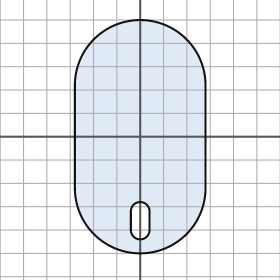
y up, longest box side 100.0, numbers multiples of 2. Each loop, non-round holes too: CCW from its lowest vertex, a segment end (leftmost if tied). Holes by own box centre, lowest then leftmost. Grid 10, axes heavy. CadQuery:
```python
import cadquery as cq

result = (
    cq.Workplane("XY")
    .moveTo(-28.0, -22.0)
    .threePointArc((0.0, -50.0), (28.0, -22.0))
    .lineTo(28.0, 22.0)
    .threePointArc((0.0, 50.0), (-28.0, 22.0))
    .close()
    .moveTo(-4.0, -40.0)
    .threePointArc((0.0, -44.0), (4.0, -40.0))
    .lineTo(4.0, -32.0)
    .threePointArc((0.0, -28.0), (-4.0, -32.0))
    .close()
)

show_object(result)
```